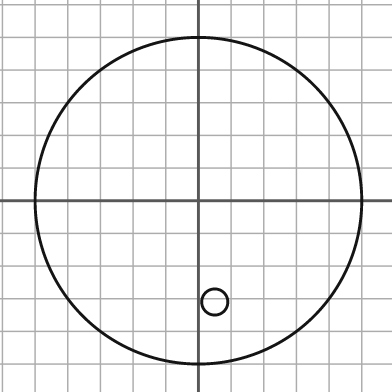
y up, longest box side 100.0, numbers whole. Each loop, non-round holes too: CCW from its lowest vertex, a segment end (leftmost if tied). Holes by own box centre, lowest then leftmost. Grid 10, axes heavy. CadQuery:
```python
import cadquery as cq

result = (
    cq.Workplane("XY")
    .moveTo(0.0, 0.0)
    .circle(50.0)
    .moveTo(5.0, -31.0)
    .circle(4.0)
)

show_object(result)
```